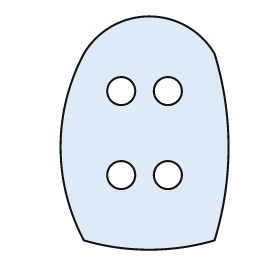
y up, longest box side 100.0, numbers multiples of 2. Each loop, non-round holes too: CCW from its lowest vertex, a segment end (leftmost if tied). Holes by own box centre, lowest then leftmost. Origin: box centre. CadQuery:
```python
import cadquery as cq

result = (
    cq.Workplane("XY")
    .moveTo(-26.0, -46.0)
    .threePointArc((2.0, -50.0), (30.0, -46.0))
    .threePointArc((36.0, -6.0), (30.0, 34.0))
    .threePointArc((2.0, 50.0), (-26.0, 34.0))
    .threePointArc((-36.0, -6.0), (-26.0, -46.0))
    .close()
    .moveTo(-10.0, -18.0)
    .circle(6.0)
    .moveTo(10.0, -18.0)
    .circle(6.0)
    .moveTo(-10.0, 18.0)
    .circle(6.0)
    .moveTo(10.0, 18.0)
    .circle(6.0)
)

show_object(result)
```